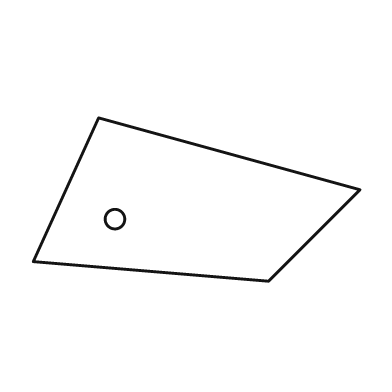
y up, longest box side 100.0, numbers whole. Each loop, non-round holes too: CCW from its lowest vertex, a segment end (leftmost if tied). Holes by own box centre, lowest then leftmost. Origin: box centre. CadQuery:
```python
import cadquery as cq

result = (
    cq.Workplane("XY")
    .moveTo(22.0, -25.0)
    .lineTo(50.0, 3.0)
    .lineTo(-30.0, 25.0)
    .lineTo(-50.0, -19.0)
    .close()
    .moveTo(-25.0, -6.0)
    .circle(3.0)
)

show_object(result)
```